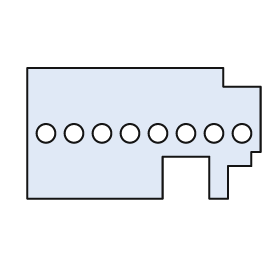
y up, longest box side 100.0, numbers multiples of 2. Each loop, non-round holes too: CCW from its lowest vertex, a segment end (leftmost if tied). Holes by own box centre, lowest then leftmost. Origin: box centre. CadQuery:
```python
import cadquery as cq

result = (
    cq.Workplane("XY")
    .moveTo(-50.0, -28.0)
    .lineTo(8.0, -28.0)
    .lineTo(8.0, -10.0)
    .lineTo(28.0, -10.0)
    .lineTo(28.0, -28.0)
    .lineTo(36.0, -28.0)
    .lineTo(36.0, -14.0)
    .lineTo(46.0, -14.0)
    .lineTo(46.0, -8.0)
    .lineTo(50.0, -8.0)
    .lineTo(50.0, 20.0)
    .lineTo(34.0, 20.0)
    .lineTo(34.0, 28.0)
    .lineTo(-50.0, 28.0)
    .close()
    .moveTo(-42.0, 0.0)
    .circle(4.0)
    .moveTo(-30.0, 0.0)
    .circle(4.0)
    .moveTo(-18.0, 0.0)
    .circle(4.0)
    .moveTo(-6.0, 0.0)
    .circle(4.0)
    .moveTo(6.0, 0.0)
    .circle(4.0)
    .moveTo(18.0, 0.0)
    .circle(4.0)
    .moveTo(30.0, 0.0)
    .circle(4.0)
    .moveTo(42.0, 0.0)
    .circle(4.0)
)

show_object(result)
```